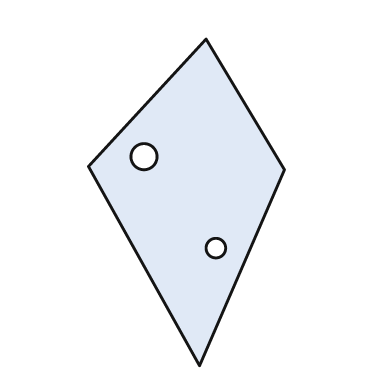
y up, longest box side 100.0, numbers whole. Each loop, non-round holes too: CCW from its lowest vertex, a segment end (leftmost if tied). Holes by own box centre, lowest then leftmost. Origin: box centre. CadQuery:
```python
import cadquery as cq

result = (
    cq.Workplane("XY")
    .moveTo(4.0, -50.0)
    .lineTo(30.0, 10.0)
    .lineTo(6.0, 50.0)
    .lineTo(-30.0, 11.0)
    .close()
    .moveTo(9.0, -14.0)
    .circle(3.0)
    .moveTo(-13.0, 14.0)
    .circle(4.0)
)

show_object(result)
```